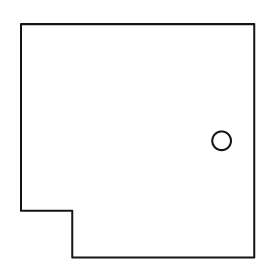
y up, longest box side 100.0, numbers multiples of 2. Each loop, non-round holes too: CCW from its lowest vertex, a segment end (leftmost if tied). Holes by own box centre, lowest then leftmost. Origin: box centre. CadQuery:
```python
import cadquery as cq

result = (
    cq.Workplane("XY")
    .moveTo(-28.0, -50.0)
    .lineTo(50.0, -50.0)
    .lineTo(50.0, 50.0)
    .lineTo(-50.0, 50.0)
    .lineTo(-50.0, -30.0)
    .lineTo(-28.0, -30.0)
    .close()
    .moveTo(36.0, 0.0)
    .circle(4.0)
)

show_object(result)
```